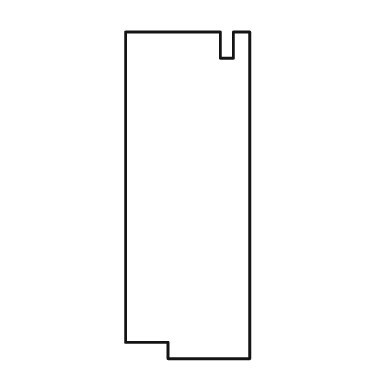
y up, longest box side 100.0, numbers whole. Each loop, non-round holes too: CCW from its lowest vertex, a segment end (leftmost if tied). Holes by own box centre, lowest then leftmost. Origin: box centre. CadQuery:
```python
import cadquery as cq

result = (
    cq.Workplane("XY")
    .moveTo(-6.0, -50.0)
    .lineTo(19.0, -50.0)
    .lineTo(19.0, 50.0)
    .lineTo(14.0, 50.0)
    .lineTo(14.0, 42.0)
    .lineTo(10.0, 42.0)
    .lineTo(10.0, 50.0)
    .lineTo(-19.0, 50.0)
    .lineTo(-19.0, -45.0)
    .lineTo(-6.0, -45.0)
    .close()
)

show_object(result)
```